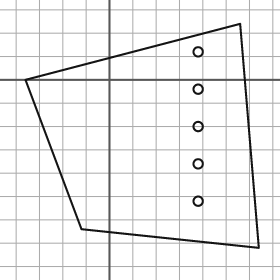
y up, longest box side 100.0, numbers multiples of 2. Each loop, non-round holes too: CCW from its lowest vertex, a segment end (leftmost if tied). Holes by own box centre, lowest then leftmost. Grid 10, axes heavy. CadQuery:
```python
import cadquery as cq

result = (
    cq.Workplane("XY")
    .moveTo(64.0, -72.0)
    .lineTo(56.0, 24.0)
    .lineTo(-36.0, 0.0)
    .lineTo(-12.0, -64.0)
    .close()
    .moveTo(38.0, -52.0)
    .circle(2.0)
    .moveTo(38.0, -36.0)
    .circle(2.0)
    .moveTo(38.0, -20.0)
    .circle(2.0)
    .moveTo(38.0, -4.0)
    .circle(2.0)
    .moveTo(38.0, 12.0)
    .circle(2.0)
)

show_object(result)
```